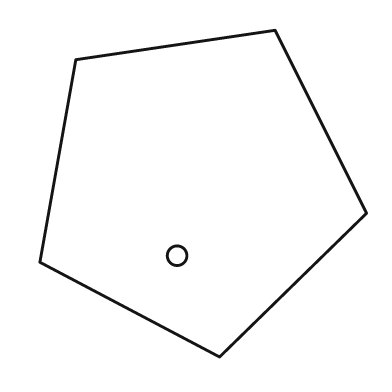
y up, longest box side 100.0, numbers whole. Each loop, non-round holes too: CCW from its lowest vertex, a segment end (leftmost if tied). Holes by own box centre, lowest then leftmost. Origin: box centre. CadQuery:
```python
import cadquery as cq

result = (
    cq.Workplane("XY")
    .moveTo(5.0, -50.0)
    .lineTo(50.0, -6.0)
    .lineTo(22.0, 50.0)
    .lineTo(-39.0, 41.0)
    .lineTo(-50.0, -21.0)
    .close()
    .moveTo(-8.0, -19.0)
    .circle(3.0)
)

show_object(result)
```